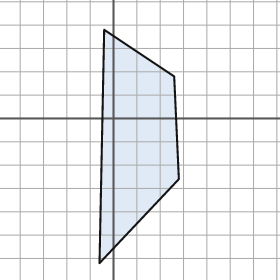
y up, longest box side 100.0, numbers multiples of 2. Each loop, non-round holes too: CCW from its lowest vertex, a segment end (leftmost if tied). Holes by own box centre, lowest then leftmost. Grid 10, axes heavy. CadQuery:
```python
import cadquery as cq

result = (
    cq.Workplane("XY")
    .moveTo(-6.0, -62.0)
    .lineTo(28.0, -26.0)
    .lineTo(26.0, 18.0)
    .lineTo(-4.0, 38.0)
    .close()
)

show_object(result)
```